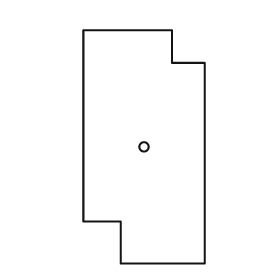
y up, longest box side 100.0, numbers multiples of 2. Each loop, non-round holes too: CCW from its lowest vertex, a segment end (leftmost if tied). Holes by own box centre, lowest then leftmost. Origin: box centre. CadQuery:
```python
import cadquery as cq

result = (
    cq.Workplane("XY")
    .moveTo(-10.0, -50.0)
    .lineTo(26.0, -50.0)
    .lineTo(26.0, 36.0)
    .lineTo(12.0, 36.0)
    .lineTo(12.0, 50.0)
    .lineTo(-26.0, 50.0)
    .lineTo(-26.0, -32.0)
    .lineTo(-10.0, -32.0)
    .close()
    .moveTo(0.0, 0.0)
    .circle(2.0)
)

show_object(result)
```